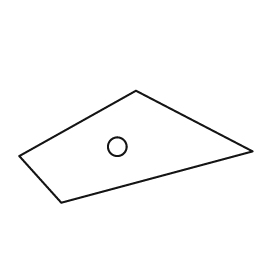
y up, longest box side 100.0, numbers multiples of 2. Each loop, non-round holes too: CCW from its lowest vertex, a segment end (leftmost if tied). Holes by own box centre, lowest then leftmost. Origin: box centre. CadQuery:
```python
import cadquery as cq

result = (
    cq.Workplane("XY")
    .moveTo(-32.0, -24.0)
    .lineTo(50.0, -2.0)
    .lineTo(0.0, 24.0)
    .lineTo(-50.0, -4.0)
    .close()
    .moveTo(-8.0, 0.0)
    .circle(4.0)
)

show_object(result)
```